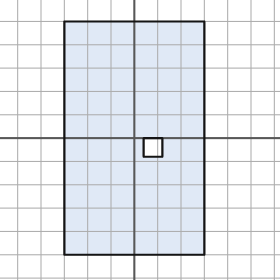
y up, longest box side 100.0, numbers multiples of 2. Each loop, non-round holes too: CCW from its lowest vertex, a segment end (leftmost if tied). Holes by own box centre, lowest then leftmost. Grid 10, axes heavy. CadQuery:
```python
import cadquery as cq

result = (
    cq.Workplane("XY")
    .moveTo(-30.0, -50.0)
    .lineTo(30.0, -50.0)
    .lineTo(30.0, 50.0)
    .lineTo(-30.0, 50.0)
    .close()
    .moveTo(4.0, -8.0)
    .lineTo(12.0, -8.0)
    .lineTo(12.0, 0.0)
    .lineTo(4.0, 0.0)
    .close()
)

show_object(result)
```